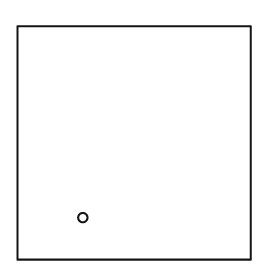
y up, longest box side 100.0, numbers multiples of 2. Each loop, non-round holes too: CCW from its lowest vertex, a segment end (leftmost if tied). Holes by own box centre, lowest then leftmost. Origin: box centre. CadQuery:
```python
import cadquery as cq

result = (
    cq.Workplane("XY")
    .moveTo(-50.0, -50.0)
    .lineTo(50.0, -50.0)
    .lineTo(50.0, 50.0)
    .lineTo(-50.0, 50.0)
    .close()
    .moveTo(-22.0, -32.0)
    .circle(2.0)
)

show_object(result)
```